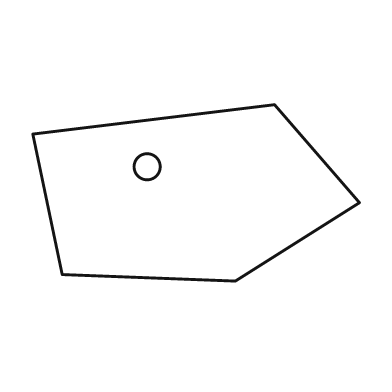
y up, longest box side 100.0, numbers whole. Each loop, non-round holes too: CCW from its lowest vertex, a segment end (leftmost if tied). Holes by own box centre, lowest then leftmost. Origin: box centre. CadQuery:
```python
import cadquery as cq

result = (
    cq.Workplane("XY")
    .moveTo(12.0, -27.0)
    .lineTo(50.0, -3.0)
    .lineTo(24.0, 27.0)
    .lineTo(-50.0, 18.0)
    .lineTo(-41.0, -25.0)
    .close()
    .moveTo(-15.0, 8.0)
    .circle(4.0)
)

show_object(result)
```